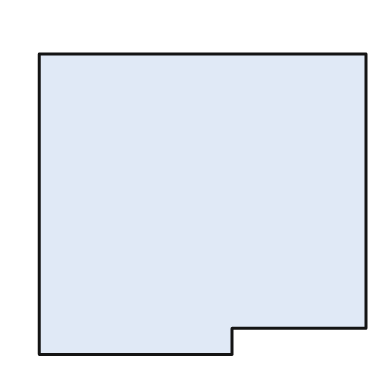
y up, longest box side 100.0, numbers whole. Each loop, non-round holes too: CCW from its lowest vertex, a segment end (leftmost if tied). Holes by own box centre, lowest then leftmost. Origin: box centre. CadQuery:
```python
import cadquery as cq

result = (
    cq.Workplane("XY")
    .moveTo(-50.0, -46.0)
    .lineTo(9.0, -46.0)
    .lineTo(9.0, -38.0)
    .lineTo(50.0, -38.0)
    .lineTo(50.0, 46.0)
    .lineTo(-50.0, 46.0)
    .close()
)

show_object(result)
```